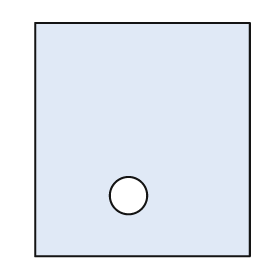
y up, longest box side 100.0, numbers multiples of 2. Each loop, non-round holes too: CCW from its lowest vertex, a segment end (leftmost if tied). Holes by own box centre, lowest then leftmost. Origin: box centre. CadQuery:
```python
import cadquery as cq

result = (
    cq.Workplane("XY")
    .moveTo(-46.0, -50.0)
    .lineTo(46.0, -50.0)
    .lineTo(46.0, 50.0)
    .lineTo(-46.0, 50.0)
    .close()
    .moveTo(-6.0, -24.0)
    .circle(8.0)
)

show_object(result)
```